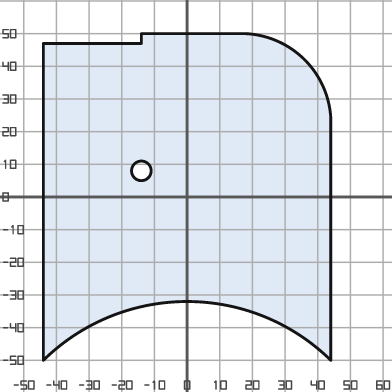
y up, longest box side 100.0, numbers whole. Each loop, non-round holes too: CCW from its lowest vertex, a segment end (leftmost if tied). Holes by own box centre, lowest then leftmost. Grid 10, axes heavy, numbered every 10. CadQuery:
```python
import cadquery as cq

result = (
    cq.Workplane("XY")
    .moveTo(-44.0, -50.0)
    .threePointArc((0.0, -32.0), (44.0, -50.0))
    .lineTo(44.0, 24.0)
    .threePointArc((36.0, 42.0), (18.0, 50.0))
    .lineTo(-14.0, 50.0)
    .lineTo(-14.0, 47.0)
    .lineTo(-44.0, 47.0)
    .close()
    .moveTo(-14.0, 8.0)
    .circle(3.0)
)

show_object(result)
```